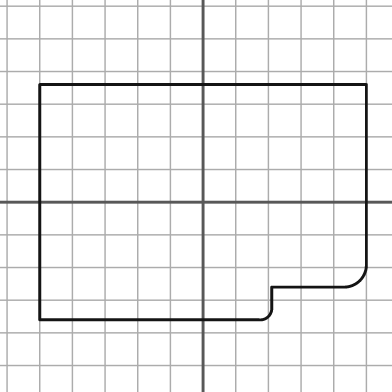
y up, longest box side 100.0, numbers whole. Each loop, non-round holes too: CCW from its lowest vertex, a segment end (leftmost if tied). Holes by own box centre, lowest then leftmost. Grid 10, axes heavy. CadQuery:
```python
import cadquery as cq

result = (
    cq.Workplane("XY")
    .moveTo(-50.0, -36.0)
    .lineTo(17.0, -36.0)
    .threePointArc((20.0, -35.0), (21.0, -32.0))
    .lineTo(21.0, -26.0)
    .lineTo(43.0, -26.0)
    .threePointArc((48.0, -24.0), (50.0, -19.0))
    .lineTo(50.0, 36.0)
    .lineTo(-50.0, 36.0)
    .close()
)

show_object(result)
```